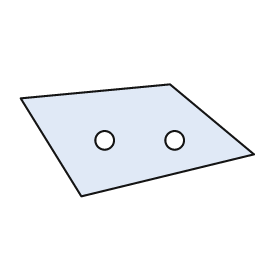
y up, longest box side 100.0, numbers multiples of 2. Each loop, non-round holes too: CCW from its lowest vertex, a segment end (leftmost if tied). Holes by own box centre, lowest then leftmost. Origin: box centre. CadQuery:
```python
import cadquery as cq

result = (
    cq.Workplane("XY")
    .moveTo(-24.0, -24.0)
    .lineTo(50.0, -6.0)
    .lineTo(14.0, 24.0)
    .lineTo(-50.0, 18.0)
    .close()
    .moveTo(-14.0, 0.0)
    .circle(4.0)
    .moveTo(16.0, 0.0)
    .circle(4.0)
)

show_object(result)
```